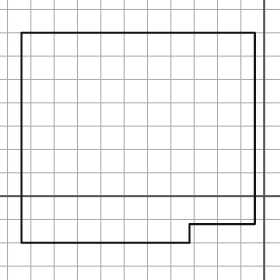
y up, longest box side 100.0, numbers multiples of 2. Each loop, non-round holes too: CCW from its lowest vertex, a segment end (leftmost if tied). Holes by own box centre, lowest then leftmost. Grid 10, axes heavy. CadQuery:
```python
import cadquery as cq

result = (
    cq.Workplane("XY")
    .moveTo(-104.0, -20.0)
    .lineTo(-32.0, -20.0)
    .lineTo(-32.0, -12.0)
    .lineTo(-4.0, -12.0)
    .lineTo(-4.0, 70.0)
    .lineTo(-104.0, 70.0)
    .close()
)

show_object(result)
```